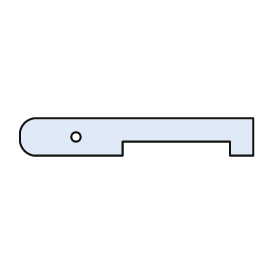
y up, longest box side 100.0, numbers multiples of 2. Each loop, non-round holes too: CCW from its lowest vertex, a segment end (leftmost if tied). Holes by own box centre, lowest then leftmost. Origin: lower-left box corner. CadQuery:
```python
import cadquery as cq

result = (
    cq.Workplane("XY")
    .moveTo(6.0, 0.0)
    .lineTo(44.0, 0.0)
    .lineTo(44.0, 6.0)
    .lineTo(90.0, 6.0)
    .lineTo(90.0, 0.0)
    .lineTo(100.0, 0.0)
    .lineTo(100.0, 16.0)
    .lineTo(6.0, 16.0)
    .threePointArc((2.0, 14.0), (0.0, 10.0))
    .lineTo(0.0, 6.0)
    .threePointArc((2.0, 2.0), (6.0, 0.0))
    .close()
    .moveTo(24.0, 8.0)
    .circle(2.0)
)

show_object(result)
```